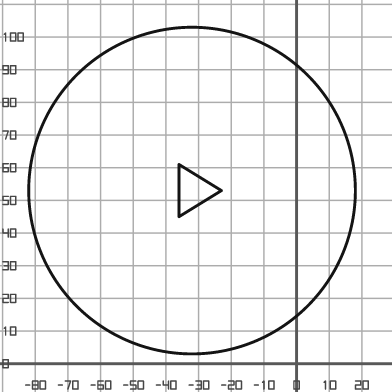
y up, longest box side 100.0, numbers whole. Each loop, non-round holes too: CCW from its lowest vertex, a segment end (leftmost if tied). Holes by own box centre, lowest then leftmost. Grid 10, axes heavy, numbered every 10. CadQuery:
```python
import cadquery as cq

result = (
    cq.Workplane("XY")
    .moveTo(-32.0, 53.0)
    .circle(50.0)
    .moveTo(-36.0, 45.0)
    .lineTo(-23.0, 53.0)
    .lineTo(-36.0, 61.0)
    .close()
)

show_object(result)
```